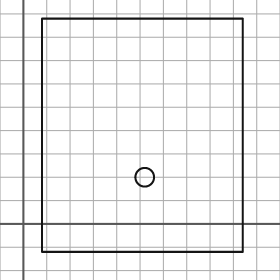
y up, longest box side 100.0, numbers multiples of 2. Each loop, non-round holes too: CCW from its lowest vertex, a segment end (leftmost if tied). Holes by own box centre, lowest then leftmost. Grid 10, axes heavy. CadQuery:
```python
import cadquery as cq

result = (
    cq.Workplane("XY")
    .moveTo(8.0, -12.0)
    .lineTo(94.0, -12.0)
    .lineTo(94.0, 88.0)
    .lineTo(8.0, 88.0)
    .close()
    .moveTo(52.0, 20.0)
    .circle(4.0)
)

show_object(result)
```